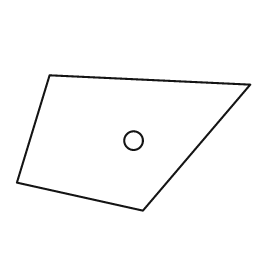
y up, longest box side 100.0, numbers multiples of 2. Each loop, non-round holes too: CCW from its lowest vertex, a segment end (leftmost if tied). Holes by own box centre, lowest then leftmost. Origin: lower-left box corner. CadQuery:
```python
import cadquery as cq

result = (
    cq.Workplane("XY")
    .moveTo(54.0, 0.0)
    .lineTo(100.0, 54.0)
    .lineTo(14.0, 58.0)
    .lineTo(0.0, 12.0)
    .close()
    .moveTo(50.0, 30.0)
    .circle(4.0)
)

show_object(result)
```